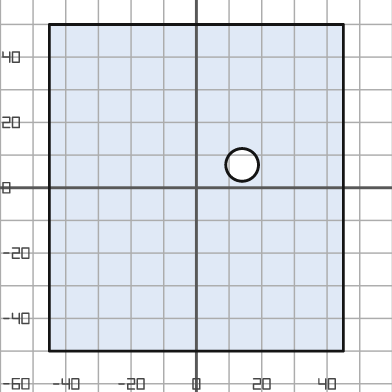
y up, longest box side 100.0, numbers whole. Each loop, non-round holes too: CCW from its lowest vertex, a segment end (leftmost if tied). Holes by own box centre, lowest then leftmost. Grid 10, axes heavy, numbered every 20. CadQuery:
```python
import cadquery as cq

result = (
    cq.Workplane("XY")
    .moveTo(-45.0, -50.0)
    .lineTo(45.0, -50.0)
    .lineTo(45.0, 50.0)
    .lineTo(-45.0, 50.0)
    .close()
    .moveTo(14.0, 7.0)
    .circle(5.0)
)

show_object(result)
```